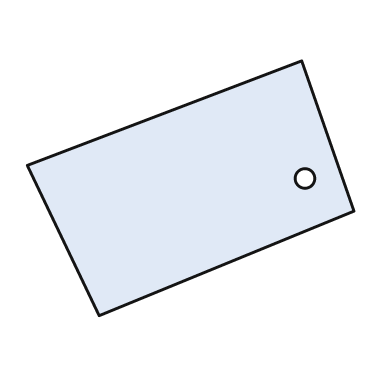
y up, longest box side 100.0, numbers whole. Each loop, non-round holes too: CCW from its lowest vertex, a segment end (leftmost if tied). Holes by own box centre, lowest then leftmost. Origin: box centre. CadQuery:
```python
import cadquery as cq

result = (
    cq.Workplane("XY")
    .moveTo(-28.0, -39.0)
    .lineTo(50.0, -7.0)
    .lineTo(34.0, 39.0)
    .lineTo(-50.0, 7.0)
    .close()
    .moveTo(35.0, 3.0)
    .circle(3.0)
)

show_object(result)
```